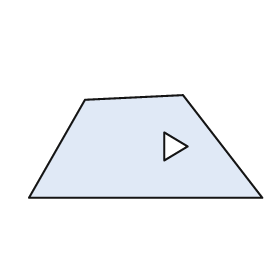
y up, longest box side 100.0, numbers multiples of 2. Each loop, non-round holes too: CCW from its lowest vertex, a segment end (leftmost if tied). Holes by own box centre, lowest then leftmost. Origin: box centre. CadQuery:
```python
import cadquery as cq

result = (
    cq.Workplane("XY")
    .moveTo(-50.0, -22.0)
    .lineTo(50.0, -22.0)
    .lineTo(16.0, 22.0)
    .lineTo(-26.0, 20.0)
    .close()
    .moveTo(8.0, -6.0)
    .lineTo(18.0, 0.0)
    .lineTo(8.0, 6.0)
    .close()
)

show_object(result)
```